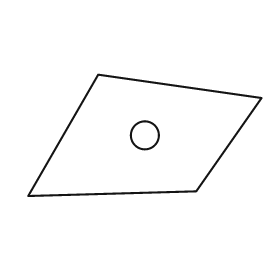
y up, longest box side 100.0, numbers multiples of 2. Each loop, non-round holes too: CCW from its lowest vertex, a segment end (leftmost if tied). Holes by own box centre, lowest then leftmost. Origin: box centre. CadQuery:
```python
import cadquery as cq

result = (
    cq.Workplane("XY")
    .moveTo(-50.0, -26.0)
    .lineTo(22.0, -24.0)
    .lineTo(50.0, 16.0)
    .lineTo(-20.0, 26.0)
    .close()
    .moveTo(0.0, 0.0)
    .circle(6.0)
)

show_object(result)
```